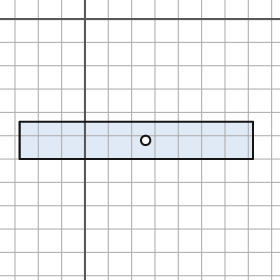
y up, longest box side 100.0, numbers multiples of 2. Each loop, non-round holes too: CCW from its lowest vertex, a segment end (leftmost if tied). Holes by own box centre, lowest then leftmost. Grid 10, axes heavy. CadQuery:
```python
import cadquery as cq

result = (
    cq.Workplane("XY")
    .moveTo(-28.0, -60.0)
    .lineTo(72.0, -60.0)
    .lineTo(72.0, -44.0)
    .lineTo(-28.0, -44.0)
    .close()
    .moveTo(26.0, -52.0)
    .circle(2.0)
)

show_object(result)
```